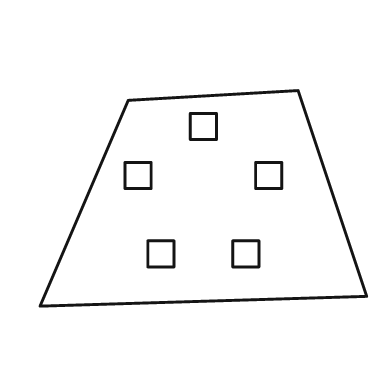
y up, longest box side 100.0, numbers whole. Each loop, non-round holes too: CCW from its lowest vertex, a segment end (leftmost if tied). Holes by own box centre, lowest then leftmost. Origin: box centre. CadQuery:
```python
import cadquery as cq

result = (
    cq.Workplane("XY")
    .moveTo(-50.0, -33.0)
    .lineTo(50.0, -30.0)
    .lineTo(29.0, 33.0)
    .lineTo(-23.0, 30.0)
    .close()
    .moveTo(-17.0, -21.0)
    .lineTo(-9.0, -21.0)
    .lineTo(-9.0, -13.0)
    .lineTo(-17.0, -13.0)
    .close()
    .moveTo(9.0, -21.0)
    .lineTo(17.0, -21.0)
    .lineTo(17.0, -13.0)
    .lineTo(9.0, -13.0)
    .close()
    .moveTo(-24.0, 3.0)
    .lineTo(-16.0, 3.0)
    .lineTo(-16.0, 11.0)
    .lineTo(-24.0, 11.0)
    .close()
    .moveTo(16.0, 3.0)
    .lineTo(24.0, 3.0)
    .lineTo(24.0, 11.0)
    .lineTo(16.0, 11.0)
    .close()
    .moveTo(-4.0, 18.0)
    .lineTo(4.0, 18.0)
    .lineTo(4.0, 26.0)
    .lineTo(-4.0, 26.0)
    .close()
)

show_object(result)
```